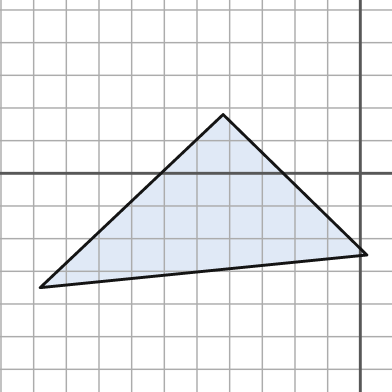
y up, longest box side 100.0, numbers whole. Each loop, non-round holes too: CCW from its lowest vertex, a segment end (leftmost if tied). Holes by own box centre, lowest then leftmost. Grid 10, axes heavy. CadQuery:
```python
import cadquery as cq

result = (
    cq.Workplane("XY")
    .moveTo(-98.0, -35.0)
    .lineTo(2.0, -25.0)
    .lineTo(-42.0, 18.0)
    .close()
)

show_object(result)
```